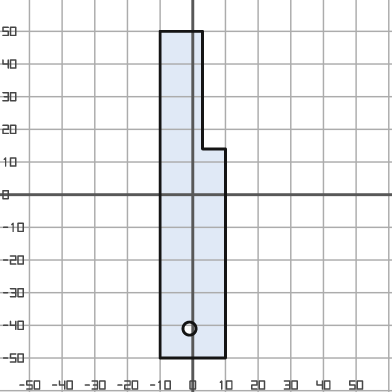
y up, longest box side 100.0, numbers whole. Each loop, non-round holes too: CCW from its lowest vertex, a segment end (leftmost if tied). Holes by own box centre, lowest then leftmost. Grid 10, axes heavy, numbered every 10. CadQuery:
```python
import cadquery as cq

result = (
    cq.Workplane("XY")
    .moveTo(-10.0, -50.0)
    .lineTo(10.0, -50.0)
    .lineTo(10.0, 14.0)
    .lineTo(3.0, 14.0)
    .lineTo(3.0, 50.0)
    .lineTo(-10.0, 50.0)
    .close()
    .moveTo(-1.0, -41.0)
    .circle(2.0)
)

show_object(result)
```